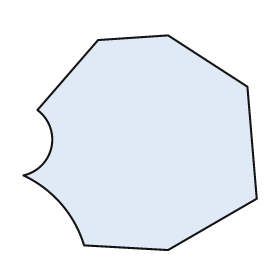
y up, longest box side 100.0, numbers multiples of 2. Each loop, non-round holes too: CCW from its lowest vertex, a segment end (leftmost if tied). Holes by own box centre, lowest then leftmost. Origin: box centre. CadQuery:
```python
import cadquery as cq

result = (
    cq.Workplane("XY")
    .moveTo(12.0, -46.0)
    .lineTo(50.0, -24.0)
    .lineTo(46.0, 24.0)
    .lineTo(12.0, 46.0)
    .lineTo(-18.0, 44.0)
    .lineTo(-44.0, 14.0)
    .threePointArc((-38.0, -2.0), (-50.0, -14.0))
    .threePointArc((-34.0, -26.0), (-24.0, -44.0))
    .close()
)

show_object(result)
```